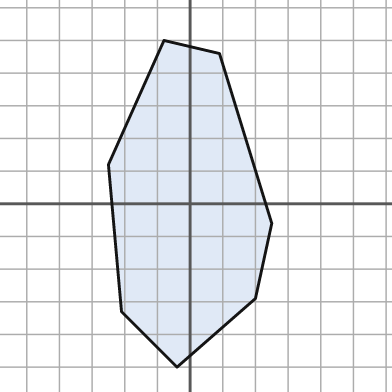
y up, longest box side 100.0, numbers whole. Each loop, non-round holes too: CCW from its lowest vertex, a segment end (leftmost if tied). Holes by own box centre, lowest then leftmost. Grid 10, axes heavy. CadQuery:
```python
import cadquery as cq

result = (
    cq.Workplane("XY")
    .moveTo(-4.0, -50.0)
    .lineTo(20.0, -29.0)
    .lineTo(25.0, -6.0)
    .lineTo(9.0, 46.0)
    .lineTo(-8.0, 50.0)
    .lineTo(-25.0, 12.0)
    .lineTo(-21.0, -33.0)
    .close()
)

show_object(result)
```